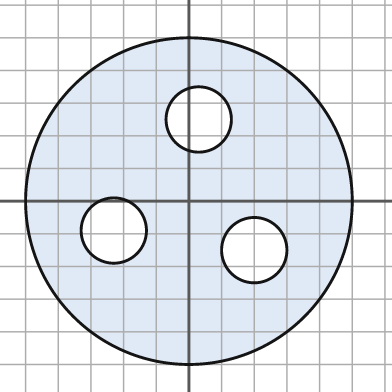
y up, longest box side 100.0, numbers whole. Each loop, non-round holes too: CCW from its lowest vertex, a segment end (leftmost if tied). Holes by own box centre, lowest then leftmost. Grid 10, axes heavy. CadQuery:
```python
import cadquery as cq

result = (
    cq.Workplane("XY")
    .moveTo(0.0, 0.0)
    .circle(50.0)
    .moveTo(20.0, -15.0)
    .circle(10.0)
    .moveTo(-23.0, -9.0)
    .circle(10.0)
    .moveTo(3.0, 25.0)
    .circle(10.0)
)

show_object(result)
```